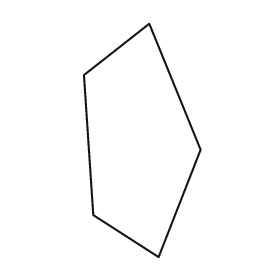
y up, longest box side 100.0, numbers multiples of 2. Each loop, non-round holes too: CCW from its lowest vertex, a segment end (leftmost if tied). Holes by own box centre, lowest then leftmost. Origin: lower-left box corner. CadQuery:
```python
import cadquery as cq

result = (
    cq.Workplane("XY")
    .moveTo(32.0, 0.0)
    .lineTo(50.0, 46.0)
    .lineTo(28.0, 100.0)
    .lineTo(0.0, 78.0)
    .lineTo(4.0, 18.0)
    .close()
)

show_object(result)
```